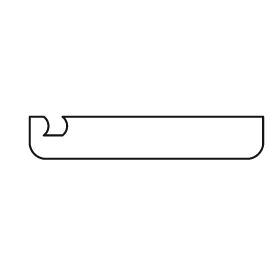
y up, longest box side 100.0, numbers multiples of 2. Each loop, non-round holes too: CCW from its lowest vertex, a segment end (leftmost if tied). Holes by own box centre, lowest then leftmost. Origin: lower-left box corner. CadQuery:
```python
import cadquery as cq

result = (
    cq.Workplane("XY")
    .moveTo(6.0, 0.0)
    .lineTo(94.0, 0.0)
    .threePointArc((98.0, 2.0), (100.0, 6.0))
    .lineTo(100.0, 18.0)
    .lineTo(14.0, 18.0)
    .threePointArc((16.0, 14.0), (14.0, 10.0))
    .lineTo(6.0, 10.0)
    .threePointArc((8.0, 14.0), (6.0, 18.0))
    .lineTo(0.0, 18.0)
    .lineTo(0.0, 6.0)
    .threePointArc((2.0, 2.0), (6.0, 0.0))
    .close()
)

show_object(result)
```